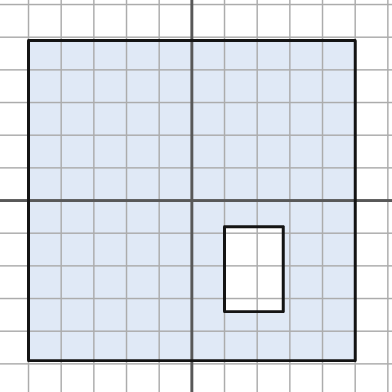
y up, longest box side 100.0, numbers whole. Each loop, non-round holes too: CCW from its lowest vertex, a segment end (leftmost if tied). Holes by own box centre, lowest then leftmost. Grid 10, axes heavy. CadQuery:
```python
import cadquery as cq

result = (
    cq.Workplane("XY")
    .moveTo(-50.0, -49.0)
    .lineTo(50.0, -49.0)
    .lineTo(50.0, 49.0)
    .lineTo(-50.0, 49.0)
    .close()
    .moveTo(10.0, -34.0)
    .lineTo(28.0, -34.0)
    .lineTo(28.0, -8.0)
    .lineTo(10.0, -8.0)
    .close()
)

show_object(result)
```